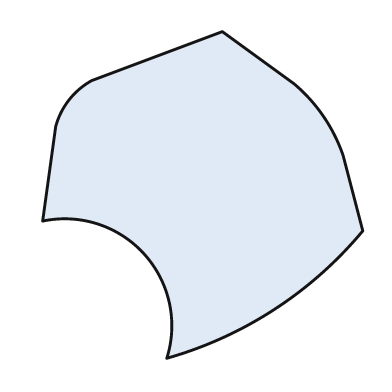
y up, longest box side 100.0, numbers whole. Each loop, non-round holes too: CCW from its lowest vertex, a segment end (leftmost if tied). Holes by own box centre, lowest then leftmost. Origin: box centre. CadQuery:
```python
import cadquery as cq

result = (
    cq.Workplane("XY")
    .moveTo(-11.0, -50.0)
    .threePointArc((22.0, -35.0), (49.0, -11.0))
    .lineTo(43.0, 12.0)
    .threePointArc((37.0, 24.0), (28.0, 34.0))
    .lineTo(6.0, 50.0)
    .lineTo(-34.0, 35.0)
    .threePointArc((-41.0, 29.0), (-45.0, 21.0))
    .lineTo(-49.0, -8.0)
    .threePointArc((-18.0, -18.0), (-11.0, -50.0))
    .close()
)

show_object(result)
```